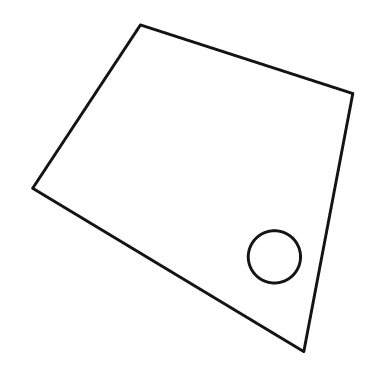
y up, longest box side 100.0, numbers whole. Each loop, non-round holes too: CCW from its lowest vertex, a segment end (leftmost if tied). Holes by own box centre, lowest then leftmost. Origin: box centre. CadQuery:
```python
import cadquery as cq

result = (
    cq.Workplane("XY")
    .moveTo(34.0, -50.0)
    .lineTo(49.0, 29.0)
    .lineTo(-16.0, 50.0)
    .lineTo(-49.0, 0.0)
    .close()
    .moveTo(25.0, -21.0)
    .circle(8.0)
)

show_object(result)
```